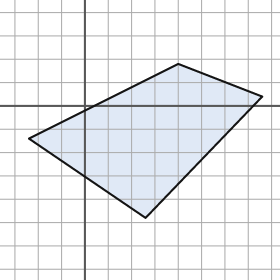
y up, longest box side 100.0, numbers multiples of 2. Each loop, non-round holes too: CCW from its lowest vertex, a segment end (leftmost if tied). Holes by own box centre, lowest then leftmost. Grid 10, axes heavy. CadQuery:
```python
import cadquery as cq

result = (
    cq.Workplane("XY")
    .moveTo(26.0, -48.0)
    .lineTo(76.0, 4.0)
    .lineTo(40.0, 18.0)
    .lineTo(-24.0, -14.0)
    .close()
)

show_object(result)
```